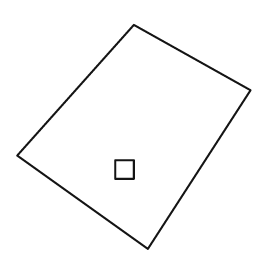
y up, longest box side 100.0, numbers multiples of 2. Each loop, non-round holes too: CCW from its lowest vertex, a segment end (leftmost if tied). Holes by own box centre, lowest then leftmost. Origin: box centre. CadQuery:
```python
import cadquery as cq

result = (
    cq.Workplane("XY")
    .moveTo(6.0, -48.0)
    .lineTo(50.0, 20.0)
    .lineTo(0.0, 48.0)
    .lineTo(-50.0, -8.0)
    .close()
    .moveTo(-8.0, -18.0)
    .lineTo(0.0, -18.0)
    .lineTo(0.0, -10.0)
    .lineTo(-8.0, -10.0)
    .close()
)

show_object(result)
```